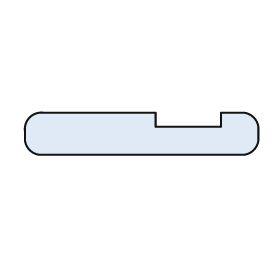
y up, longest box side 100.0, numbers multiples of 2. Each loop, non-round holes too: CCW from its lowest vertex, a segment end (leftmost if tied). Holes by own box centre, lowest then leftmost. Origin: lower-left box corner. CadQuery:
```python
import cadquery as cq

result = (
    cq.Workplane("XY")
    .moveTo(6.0, 0.0)
    .lineTo(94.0, 0.0)
    .threePointArc((98.0, 2.0), (100.0, 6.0))
    .lineTo(100.0, 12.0)
    .threePointArc((98.0, 16.0), (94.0, 18.0))
    .lineTo(84.0, 18.0)
    .lineTo(84.0, 12.0)
    .lineTo(56.0, 12.0)
    .lineTo(56.0, 18.0)
    .lineTo(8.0, 18.0)
    .threePointArc((2.0, 16.0), (0.0, 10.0))
    .lineTo(0.0, 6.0)
    .threePointArc((2.0, 2.0), (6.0, 0.0))
    .close()
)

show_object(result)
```